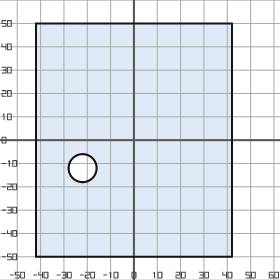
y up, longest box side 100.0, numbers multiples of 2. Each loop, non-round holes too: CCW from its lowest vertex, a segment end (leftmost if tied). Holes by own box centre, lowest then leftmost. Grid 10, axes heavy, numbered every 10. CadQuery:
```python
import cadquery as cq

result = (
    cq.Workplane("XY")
    .moveTo(-42.0, -50.0)
    .lineTo(42.0, -50.0)
    .lineTo(42.0, 50.0)
    .lineTo(-42.0, 50.0)
    .close()
    .moveTo(-22.0, -12.0)
    .circle(6.0)
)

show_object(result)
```